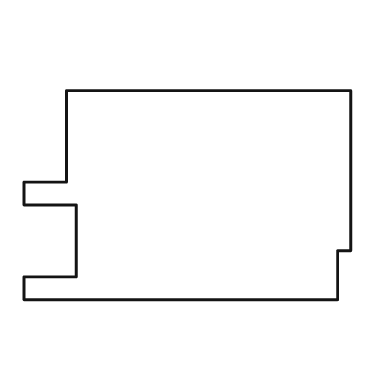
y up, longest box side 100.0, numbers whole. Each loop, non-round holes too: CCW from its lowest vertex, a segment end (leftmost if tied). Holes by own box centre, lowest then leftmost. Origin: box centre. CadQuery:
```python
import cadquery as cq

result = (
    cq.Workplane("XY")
    .moveTo(-50.0, -32.0)
    .lineTo(46.0, -32.0)
    .lineTo(46.0, -17.0)
    .lineTo(50.0, -17.0)
    .lineTo(50.0, 32.0)
    .lineTo(-37.0, 32.0)
    .lineTo(-37.0, 4.0)
    .lineTo(-50.0, 4.0)
    .lineTo(-50.0, -3.0)
    .lineTo(-34.0, -3.0)
    .lineTo(-34.0, -25.0)
    .lineTo(-50.0, -25.0)
    .close()
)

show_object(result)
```